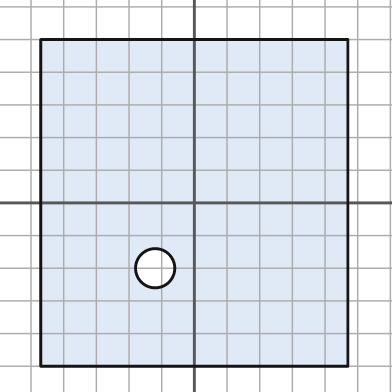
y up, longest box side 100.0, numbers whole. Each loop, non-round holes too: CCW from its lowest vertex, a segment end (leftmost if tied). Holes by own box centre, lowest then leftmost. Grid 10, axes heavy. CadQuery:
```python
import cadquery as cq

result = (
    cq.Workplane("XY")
    .moveTo(-47.0, -50.0)
    .lineTo(47.0, -50.0)
    .lineTo(47.0, 50.0)
    .lineTo(-47.0, 50.0)
    .close()
    .moveTo(-12.0, -20.0)
    .circle(6.0)
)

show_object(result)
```